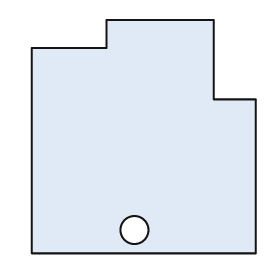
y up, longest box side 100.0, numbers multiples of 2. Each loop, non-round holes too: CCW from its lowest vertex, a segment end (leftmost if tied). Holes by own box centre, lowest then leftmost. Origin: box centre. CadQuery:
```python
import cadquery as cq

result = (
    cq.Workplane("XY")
    .moveTo(-48.0, -50.0)
    .lineTo(48.0, -50.0)
    .lineTo(48.0, 16.0)
    .lineTo(30.0, 16.0)
    .lineTo(30.0, 50.0)
    .lineTo(-16.0, 50.0)
    .lineTo(-16.0, 38.0)
    .lineTo(-48.0, 38.0)
    .close()
    .moveTo(-4.0, -40.0)
    .circle(6.0)
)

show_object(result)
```